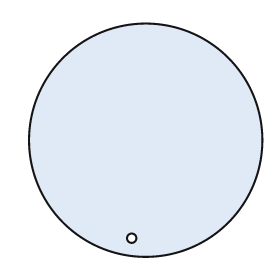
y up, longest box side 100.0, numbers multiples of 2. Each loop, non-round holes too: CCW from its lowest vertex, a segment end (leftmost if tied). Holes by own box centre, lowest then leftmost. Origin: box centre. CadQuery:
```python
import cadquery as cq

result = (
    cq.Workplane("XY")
    .moveTo(0.0, 0.0)
    .circle(50.0)
    .moveTo(-6.0, -42.0)
    .circle(2.0)
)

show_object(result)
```